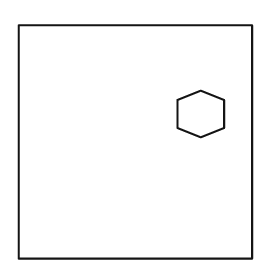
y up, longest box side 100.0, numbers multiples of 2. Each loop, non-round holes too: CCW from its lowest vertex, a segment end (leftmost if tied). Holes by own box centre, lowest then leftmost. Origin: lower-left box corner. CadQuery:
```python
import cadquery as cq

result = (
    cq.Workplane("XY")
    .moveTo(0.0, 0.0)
    .lineTo(100.0, 0.0)
    .lineTo(100.0, 100.0)
    .lineTo(0.0, 100.0)
    .close()
    .moveTo(78.0, 52.0)
    .lineTo(88.0, 56.0)
    .lineTo(88.0, 68.0)
    .lineTo(78.0, 72.0)
    .lineTo(68.0, 68.0)
    .lineTo(68.0, 56.0)
    .close()
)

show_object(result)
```